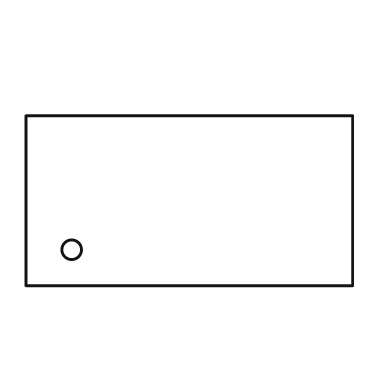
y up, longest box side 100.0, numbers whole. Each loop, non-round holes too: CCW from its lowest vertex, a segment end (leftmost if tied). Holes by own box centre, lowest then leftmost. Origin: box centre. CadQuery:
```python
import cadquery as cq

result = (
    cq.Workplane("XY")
    .moveTo(-50.0, -26.0)
    .lineTo(50.0, -26.0)
    .lineTo(50.0, 26.0)
    .lineTo(-50.0, 26.0)
    .close()
    .moveTo(-36.0, -15.0)
    .circle(3.0)
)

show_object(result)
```